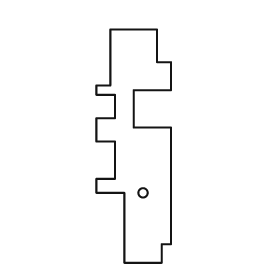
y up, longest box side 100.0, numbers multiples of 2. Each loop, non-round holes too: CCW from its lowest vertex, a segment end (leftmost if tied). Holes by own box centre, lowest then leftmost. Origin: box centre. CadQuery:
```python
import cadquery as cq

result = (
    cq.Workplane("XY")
    .moveTo(-4.0, -50.0)
    .lineTo(12.0, -50.0)
    .lineTo(12.0, -42.0)
    .lineTo(16.0, -42.0)
    .lineTo(16.0, 8.0)
    .lineTo(0.0, 8.0)
    .lineTo(0.0, 24.0)
    .lineTo(16.0, 24.0)
    .lineTo(16.0, 36.0)
    .lineTo(10.0, 36.0)
    .lineTo(10.0, 50.0)
    .lineTo(-10.0, 50.0)
    .lineTo(-10.0, 26.0)
    .lineTo(-16.0, 26.0)
    .lineTo(-16.0, 22.0)
    .lineTo(-8.0, 22.0)
    .lineTo(-8.0, 12.0)
    .lineTo(-16.0, 12.0)
    .lineTo(-16.0, 2.0)
    .lineTo(-8.0, 2.0)
    .lineTo(-8.0, -14.0)
    .lineTo(-16.0, -14.0)
    .lineTo(-16.0, -20.0)
    .lineTo(-4.0, -20.0)
    .close()
    .moveTo(4.0, -20.0)
    .circle(2.0)
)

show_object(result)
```